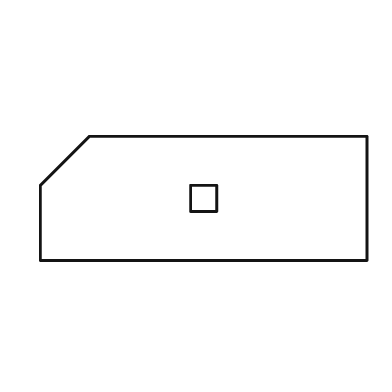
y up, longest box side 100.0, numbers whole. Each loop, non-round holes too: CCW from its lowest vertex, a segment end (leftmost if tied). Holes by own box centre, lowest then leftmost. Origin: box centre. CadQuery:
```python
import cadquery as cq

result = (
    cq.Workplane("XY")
    .moveTo(-50.0, -19.0)
    .lineTo(50.0, -19.0)
    .lineTo(50.0, 19.0)
    .lineTo(-35.0, 19.0)
    .lineTo(-50.0, 4.0)
    .close()
    .moveTo(-4.0, -4.0)
    .lineTo(4.0, -4.0)
    .lineTo(4.0, 4.0)
    .lineTo(-4.0, 4.0)
    .close()
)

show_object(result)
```